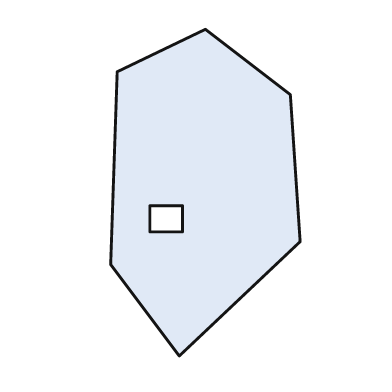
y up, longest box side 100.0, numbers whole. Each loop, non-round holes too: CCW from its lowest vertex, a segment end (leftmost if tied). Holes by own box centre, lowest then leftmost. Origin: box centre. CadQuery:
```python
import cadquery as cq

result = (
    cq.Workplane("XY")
    .moveTo(-8.0, -50.0)
    .lineTo(29.0, -15.0)
    .lineTo(26.0, 30.0)
    .lineTo(0.0, 50.0)
    .lineTo(-27.0, 37.0)
    .lineTo(-29.0, -22.0)
    .close()
    .moveTo(-17.0, -12.0)
    .lineTo(-7.0, -12.0)
    .lineTo(-7.0, -4.0)
    .lineTo(-17.0, -4.0)
    .close()
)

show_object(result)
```